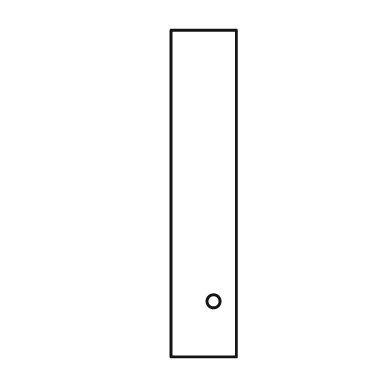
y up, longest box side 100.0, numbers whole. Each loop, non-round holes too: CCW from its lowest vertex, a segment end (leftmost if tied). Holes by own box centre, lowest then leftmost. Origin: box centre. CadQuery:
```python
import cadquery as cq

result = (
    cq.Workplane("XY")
    .moveTo(-10.0, -50.0)
    .lineTo(10.0, -50.0)
    .lineTo(10.0, 50.0)
    .lineTo(-10.0, 50.0)
    .close()
    .moveTo(3.0, -33.0)
    .circle(2.0)
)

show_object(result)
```